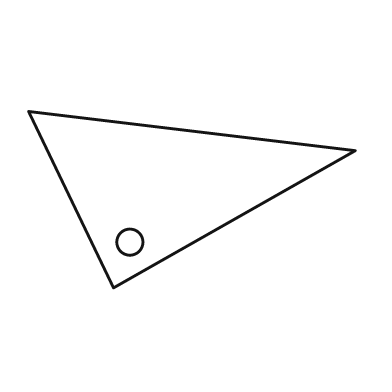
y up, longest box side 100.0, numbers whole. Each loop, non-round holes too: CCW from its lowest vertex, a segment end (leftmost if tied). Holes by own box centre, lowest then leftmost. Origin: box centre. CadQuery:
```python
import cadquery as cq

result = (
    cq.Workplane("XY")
    .moveTo(-24.0, -27.0)
    .lineTo(50.0, 15.0)
    .lineTo(-50.0, 27.0)
    .close()
    .moveTo(-19.0, -13.0)
    .circle(4.0)
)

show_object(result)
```